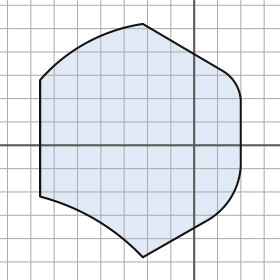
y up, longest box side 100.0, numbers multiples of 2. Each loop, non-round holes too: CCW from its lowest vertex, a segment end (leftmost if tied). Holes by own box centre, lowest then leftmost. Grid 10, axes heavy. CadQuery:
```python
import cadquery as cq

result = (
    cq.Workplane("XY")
    .moveTo(-22.0, -48.0)
    .lineTo(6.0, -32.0)
    .threePointArc((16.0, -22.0), (20.0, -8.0))
    .lineTo(20.0, 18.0)
    .threePointArc((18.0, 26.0), (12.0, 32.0))
    .lineTo(-22.0, 52.0)
    .threePointArc((-46.0, 44.0), (-66.0, 28.0))
    .lineTo(-66.0, -22.0)
    .threePointArc((-42.0, -32.0), (-22.0, -48.0))
    .close()
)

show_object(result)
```